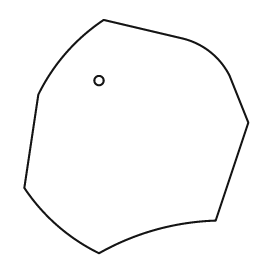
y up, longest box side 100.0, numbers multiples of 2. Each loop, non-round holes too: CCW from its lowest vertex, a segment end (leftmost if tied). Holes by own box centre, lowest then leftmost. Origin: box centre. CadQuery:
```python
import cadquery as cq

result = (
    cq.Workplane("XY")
    .moveTo(-16.0, -50.0)
    .threePointArc((8.0, -40.0), (34.0, -36.0))
    .lineTo(48.0, 6.0)
    .lineTo(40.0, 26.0)
    .threePointArc((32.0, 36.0), (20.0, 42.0))
    .lineTo(-14.0, 50.0)
    .threePointArc((-30.0, 36.0), (-42.0, 18.0))
    .lineTo(-48.0, -22.0)
    .threePointArc((-34.0, -38.0), (-16.0, -50.0))
    .close()
    .moveTo(-16.0, 24.0)
    .circle(2.0)
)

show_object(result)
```